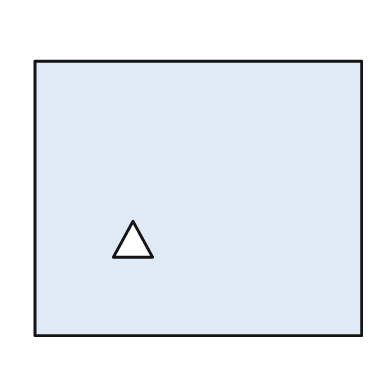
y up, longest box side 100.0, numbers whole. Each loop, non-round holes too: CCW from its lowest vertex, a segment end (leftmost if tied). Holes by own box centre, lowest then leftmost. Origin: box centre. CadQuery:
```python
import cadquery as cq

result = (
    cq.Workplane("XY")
    .moveTo(-50.0, -42.0)
    .lineTo(50.0, -42.0)
    .lineTo(50.0, 42.0)
    .lineTo(-50.0, 42.0)
    .close()
    .moveTo(-26.0, -18.0)
    .lineTo(-14.0, -18.0)
    .lineTo(-20.0, -7.0)
    .close()
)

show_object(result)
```